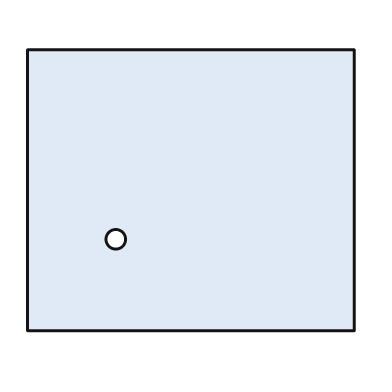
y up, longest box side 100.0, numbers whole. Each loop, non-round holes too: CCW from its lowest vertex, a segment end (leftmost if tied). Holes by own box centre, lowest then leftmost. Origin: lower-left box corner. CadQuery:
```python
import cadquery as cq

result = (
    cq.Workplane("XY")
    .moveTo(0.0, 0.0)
    .lineTo(100.0, 0.0)
    .lineTo(100.0, 86.0)
    .lineTo(0.0, 86.0)
    .close()
    .moveTo(27.0, 28.0)
    .circle(3.0)
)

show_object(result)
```